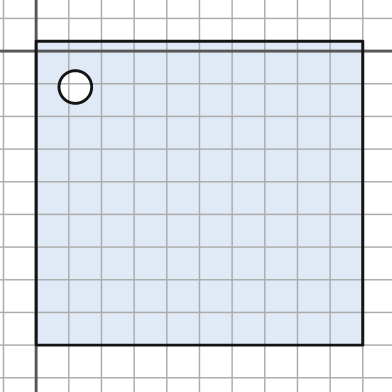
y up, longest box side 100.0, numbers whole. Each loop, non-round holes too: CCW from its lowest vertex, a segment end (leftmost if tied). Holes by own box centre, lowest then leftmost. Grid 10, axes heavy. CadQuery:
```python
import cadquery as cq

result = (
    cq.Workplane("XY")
    .moveTo(0.0, -90.0)
    .lineTo(100.0, -90.0)
    .lineTo(100.0, 3.0)
    .lineTo(0.0, 3.0)
    .close()
    .moveTo(12.0, -11.0)
    .circle(5.0)
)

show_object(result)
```